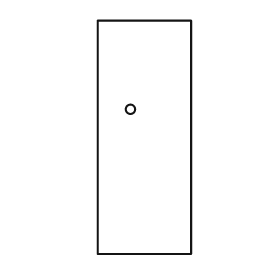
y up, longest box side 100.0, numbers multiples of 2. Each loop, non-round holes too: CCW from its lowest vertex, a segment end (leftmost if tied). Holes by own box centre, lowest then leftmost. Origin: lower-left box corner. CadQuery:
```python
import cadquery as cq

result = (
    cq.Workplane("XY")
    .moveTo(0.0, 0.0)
    .lineTo(40.0, 0.0)
    .lineTo(40.0, 100.0)
    .lineTo(0.0, 100.0)
    .close()
    .moveTo(14.0, 62.0)
    .circle(2.0)
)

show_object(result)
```